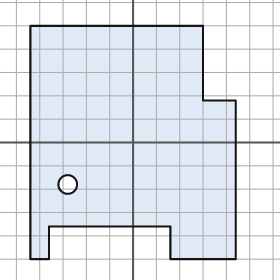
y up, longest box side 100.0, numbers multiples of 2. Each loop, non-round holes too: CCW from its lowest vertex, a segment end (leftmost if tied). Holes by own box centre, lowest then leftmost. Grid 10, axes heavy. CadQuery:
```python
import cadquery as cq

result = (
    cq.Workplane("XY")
    .moveTo(-44.0, -50.0)
    .lineTo(-36.0, -50.0)
    .lineTo(-36.0, -36.0)
    .lineTo(16.0, -36.0)
    .lineTo(16.0, -50.0)
    .lineTo(44.0, -50.0)
    .lineTo(44.0, 18.0)
    .lineTo(30.0, 18.0)
    .lineTo(30.0, 50.0)
    .lineTo(-44.0, 50.0)
    .close()
    .moveTo(-28.0, -18.0)
    .circle(4.0)
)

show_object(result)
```